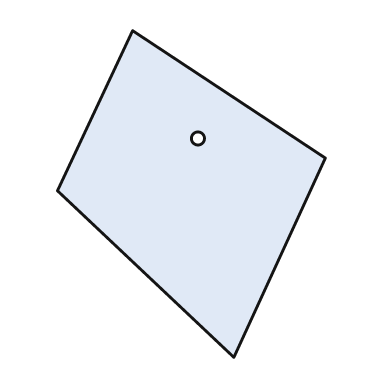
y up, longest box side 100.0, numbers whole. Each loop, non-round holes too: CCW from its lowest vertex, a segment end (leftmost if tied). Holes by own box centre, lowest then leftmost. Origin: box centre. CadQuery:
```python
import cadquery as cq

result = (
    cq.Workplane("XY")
    .moveTo(13.0, -50.0)
    .lineTo(41.0, 11.0)
    .lineTo(-18.0, 50.0)
    .lineTo(-41.0, 1.0)
    .close()
    .moveTo(2.0, 17.0)
    .circle(2.0)
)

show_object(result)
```